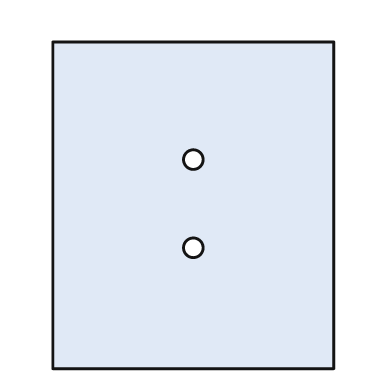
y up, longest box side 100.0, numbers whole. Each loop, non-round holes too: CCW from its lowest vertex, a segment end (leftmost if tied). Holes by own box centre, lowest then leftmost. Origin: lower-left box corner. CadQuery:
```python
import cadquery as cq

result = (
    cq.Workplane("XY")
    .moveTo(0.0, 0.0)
    .lineTo(86.0, 0.0)
    .lineTo(86.0, 100.0)
    .lineTo(0.0, 100.0)
    .close()
    .moveTo(43.0, 37.0)
    .circle(3.0)
    .moveTo(43.0, 64.0)
    .circle(3.0)
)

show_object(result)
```